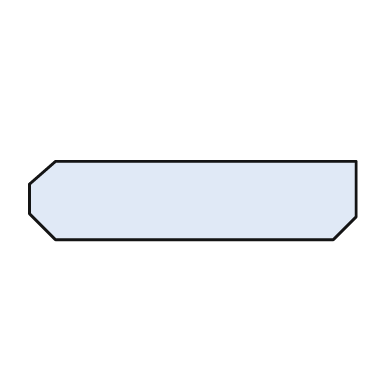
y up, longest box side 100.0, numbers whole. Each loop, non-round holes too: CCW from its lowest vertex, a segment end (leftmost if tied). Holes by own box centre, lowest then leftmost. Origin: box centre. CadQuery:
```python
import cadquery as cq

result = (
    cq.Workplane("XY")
    .moveTo(-42.0, -12.0)
    .lineTo(43.0, -12.0)
    .lineTo(50.0, -5.0)
    .lineTo(50.0, 12.0)
    .lineTo(-42.0, 12.0)
    .lineTo(-50.0, 5.0)
    .lineTo(-50.0, -4.0)
    .close()
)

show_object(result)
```